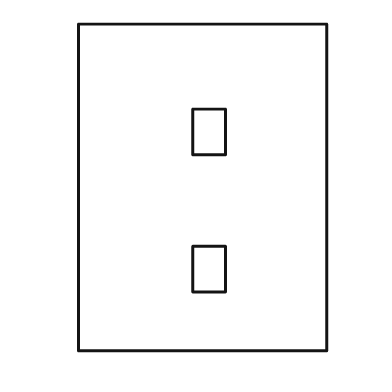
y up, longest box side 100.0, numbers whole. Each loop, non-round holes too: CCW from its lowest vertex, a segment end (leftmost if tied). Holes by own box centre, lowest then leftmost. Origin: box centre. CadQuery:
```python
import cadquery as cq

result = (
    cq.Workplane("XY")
    .moveTo(-38.0, -50.0)
    .lineTo(38.0, -50.0)
    .lineTo(38.0, 50.0)
    .lineTo(-38.0, 50.0)
    .close()
    .moveTo(-3.0, -32.0)
    .lineTo(7.0, -32.0)
    .lineTo(7.0, -18.0)
    .lineTo(-3.0, -18.0)
    .close()
    .moveTo(-3.0, 10.0)
    .lineTo(7.0, 10.0)
    .lineTo(7.0, 24.0)
    .lineTo(-3.0, 24.0)
    .close()
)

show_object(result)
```